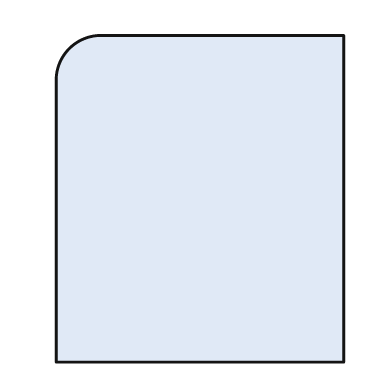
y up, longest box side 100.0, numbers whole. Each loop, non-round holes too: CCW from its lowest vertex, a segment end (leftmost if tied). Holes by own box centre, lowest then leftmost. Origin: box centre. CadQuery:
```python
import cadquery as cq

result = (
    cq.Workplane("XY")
    .moveTo(-44.0, -50.0)
    .lineTo(44.0, -50.0)
    .lineTo(44.0, 50.0)
    .lineTo(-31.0, 50.0)
    .threePointArc((-40.0, 46.0), (-44.0, 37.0))
    .close()
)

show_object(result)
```